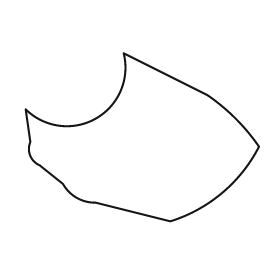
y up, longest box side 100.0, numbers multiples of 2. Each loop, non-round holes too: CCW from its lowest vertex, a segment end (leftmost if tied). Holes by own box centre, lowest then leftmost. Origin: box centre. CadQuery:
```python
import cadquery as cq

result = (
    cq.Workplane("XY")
    .moveTo(12.0, -36.0)
    .threePointArc((34.0, -24.0), (50.0, -4.0))
    .threePointArc((40.0, 8.0), (28.0, 18.0))
    .lineTo(-8.0, 36.0)
    .threePointArc((-20.0, 8.0), (-50.0, 12.0))
    .lineTo(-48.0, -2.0)
    .threePointArc((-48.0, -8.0), (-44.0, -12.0))
    .lineTo(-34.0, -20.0)
    .threePointArc((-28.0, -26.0), (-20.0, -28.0))
    .close()
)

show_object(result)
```